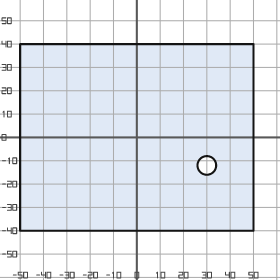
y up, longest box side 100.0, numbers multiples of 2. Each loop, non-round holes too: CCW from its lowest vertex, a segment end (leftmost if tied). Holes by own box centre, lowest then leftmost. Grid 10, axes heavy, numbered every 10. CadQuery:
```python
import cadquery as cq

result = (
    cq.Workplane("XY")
    .moveTo(-50.0, -40.0)
    .lineTo(50.0, -40.0)
    .lineTo(50.0, 40.0)
    .lineTo(-50.0, 40.0)
    .close()
    .moveTo(30.0, -12.0)
    .circle(4.0)
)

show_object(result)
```